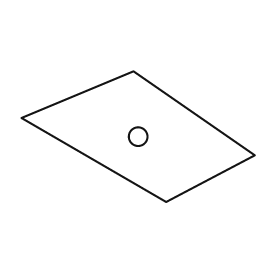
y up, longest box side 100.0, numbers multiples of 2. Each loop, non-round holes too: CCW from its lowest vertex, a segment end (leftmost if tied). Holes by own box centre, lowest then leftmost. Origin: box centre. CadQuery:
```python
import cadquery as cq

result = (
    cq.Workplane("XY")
    .moveTo(12.0, -28.0)
    .lineTo(50.0, -8.0)
    .lineTo(-2.0, 28.0)
    .lineTo(-50.0, 8.0)
    .close()
    .moveTo(0.0, 0.0)
    .circle(4.0)
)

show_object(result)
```